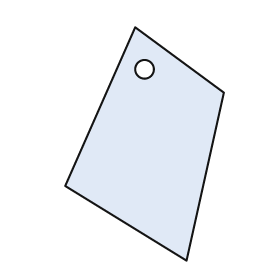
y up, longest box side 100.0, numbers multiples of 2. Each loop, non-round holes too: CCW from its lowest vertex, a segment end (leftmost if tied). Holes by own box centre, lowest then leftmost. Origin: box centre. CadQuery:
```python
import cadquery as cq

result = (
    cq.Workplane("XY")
    .moveTo(18.0, -50.0)
    .lineTo(34.0, 22.0)
    .lineTo(-4.0, 50.0)
    .lineTo(-34.0, -18.0)
    .close()
    .moveTo(0.0, 32.0)
    .circle(4.0)
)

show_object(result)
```